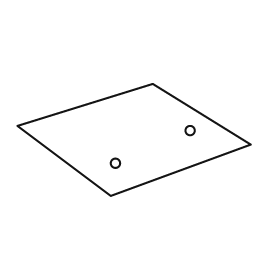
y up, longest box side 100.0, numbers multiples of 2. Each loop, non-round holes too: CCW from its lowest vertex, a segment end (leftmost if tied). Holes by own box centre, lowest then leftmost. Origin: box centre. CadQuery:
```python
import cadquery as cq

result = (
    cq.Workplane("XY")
    .moveTo(-10.0, -24.0)
    .lineTo(50.0, -2.0)
    .lineTo(8.0, 24.0)
    .lineTo(-50.0, 6.0)
    .close()
    .moveTo(-8.0, -10.0)
    .circle(2.0)
    .moveTo(24.0, 4.0)
    .circle(2.0)
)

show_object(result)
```